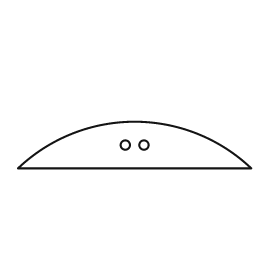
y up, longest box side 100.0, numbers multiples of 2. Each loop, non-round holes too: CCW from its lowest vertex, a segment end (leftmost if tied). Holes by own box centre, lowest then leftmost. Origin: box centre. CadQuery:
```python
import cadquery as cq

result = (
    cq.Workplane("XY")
    .moveTo(-50.0, -10.0)
    .lineTo(50.0, -10.0)
    .threePointArc((0.0, 10.0), (-50.0, -10.0))
    .close()
    .moveTo(-4.0, 0.0)
    .circle(2.0)
    .moveTo(4.0, 0.0)
    .circle(2.0)
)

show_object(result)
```